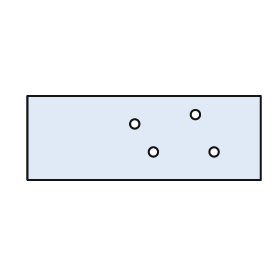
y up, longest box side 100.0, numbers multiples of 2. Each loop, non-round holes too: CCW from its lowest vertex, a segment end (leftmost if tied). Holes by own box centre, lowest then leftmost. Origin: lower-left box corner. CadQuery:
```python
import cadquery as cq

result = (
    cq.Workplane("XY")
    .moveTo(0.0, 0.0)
    .lineTo(100.0, 0.0)
    .lineTo(100.0, 36.0)
    .lineTo(0.0, 36.0)
    .close()
    .moveTo(54.0, 12.0)
    .circle(2.0)
    .moveTo(80.0, 12.0)
    .circle(2.0)
    .moveTo(46.0, 24.0)
    .circle(2.0)
    .moveTo(72.0, 28.0)
    .circle(2.0)
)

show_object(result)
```